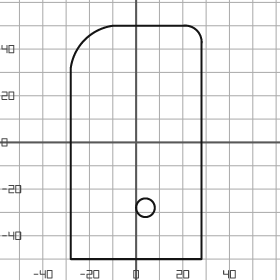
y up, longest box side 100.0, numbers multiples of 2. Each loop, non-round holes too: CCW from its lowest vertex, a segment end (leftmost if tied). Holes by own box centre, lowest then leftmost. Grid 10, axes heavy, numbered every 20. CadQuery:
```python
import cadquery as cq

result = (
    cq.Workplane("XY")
    .moveTo(-28.0, -50.0)
    .lineTo(28.0, -50.0)
    .lineTo(28.0, 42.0)
    .threePointArc((26.0, 48.0), (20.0, 50.0))
    .lineTo(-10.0, 50.0)
    .threePointArc((-22.0, 44.0), (-28.0, 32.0))
    .close()
    .moveTo(4.0, -28.0)
    .circle(4.0)
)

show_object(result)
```